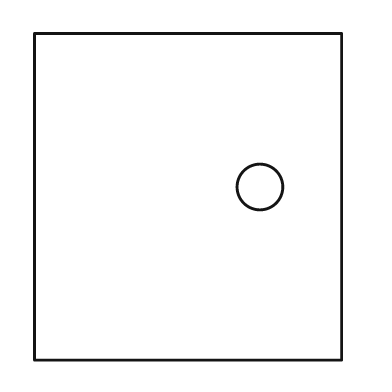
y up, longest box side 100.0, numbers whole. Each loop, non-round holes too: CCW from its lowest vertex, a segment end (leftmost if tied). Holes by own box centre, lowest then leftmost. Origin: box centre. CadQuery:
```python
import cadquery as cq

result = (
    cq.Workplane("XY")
    .moveTo(-47.0, -50.0)
    .lineTo(47.0, -50.0)
    .lineTo(47.0, 50.0)
    .lineTo(-47.0, 50.0)
    .close()
    .moveTo(22.0, 3.0)
    .circle(7.0)
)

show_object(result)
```